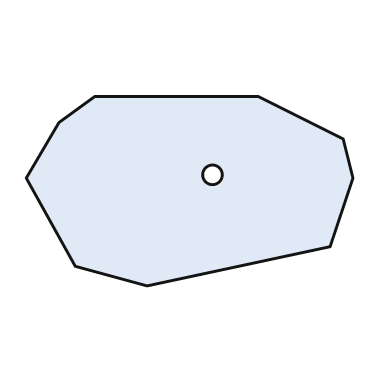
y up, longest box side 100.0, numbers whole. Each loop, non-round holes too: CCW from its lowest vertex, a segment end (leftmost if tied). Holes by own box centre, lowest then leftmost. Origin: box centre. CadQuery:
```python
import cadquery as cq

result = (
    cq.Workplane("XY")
    .moveTo(-13.0, -29.0)
    .lineTo(43.0, -17.0)
    .lineTo(50.0, 4.0)
    .lineTo(47.0, 16.0)
    .lineTo(21.0, 29.0)
    .lineTo(-29.0, 29.0)
    .lineTo(-40.0, 21.0)
    .lineTo(-50.0, 4.0)
    .lineTo(-35.0, -23.0)
    .close()
    .moveTo(7.0, 5.0)
    .circle(3.0)
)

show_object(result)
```